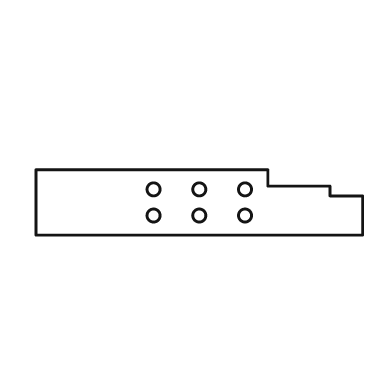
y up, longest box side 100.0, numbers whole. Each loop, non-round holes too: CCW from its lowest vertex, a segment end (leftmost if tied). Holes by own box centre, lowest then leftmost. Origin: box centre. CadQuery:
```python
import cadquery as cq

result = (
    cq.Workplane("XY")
    .moveTo(-50.0, -10.0)
    .lineTo(50.0, -10.0)
    .lineTo(50.0, 2.0)
    .lineTo(40.0, 2.0)
    .lineTo(40.0, 5.0)
    .lineTo(21.0, 5.0)
    .lineTo(21.0, 10.0)
    .lineTo(-50.0, 10.0)
    .close()
    .moveTo(-14.0, -4.0)
    .circle(2.0)
    .moveTo(0.0, -4.0)
    .circle(2.0)
    .moveTo(14.0, -4.0)
    .circle(2.0)
    .moveTo(-14.0, 4.0)
    .circle(2.0)
    .moveTo(0.0, 4.0)
    .circle(2.0)
    .moveTo(14.0, 4.0)
    .circle(2.0)
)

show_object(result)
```